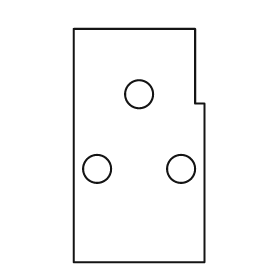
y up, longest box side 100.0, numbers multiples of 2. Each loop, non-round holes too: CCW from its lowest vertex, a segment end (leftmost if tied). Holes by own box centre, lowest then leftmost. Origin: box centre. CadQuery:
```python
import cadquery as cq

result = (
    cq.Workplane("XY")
    .moveTo(-28.0, -50.0)
    .lineTo(28.0, -50.0)
    .lineTo(28.0, 18.0)
    .lineTo(24.0, 18.0)
    .lineTo(24.0, 50.0)
    .lineTo(-28.0, 50.0)
    .close()
    .moveTo(-18.0, -10.0)
    .circle(6.0)
    .moveTo(18.0, -10.0)
    .circle(6.0)
    .moveTo(0.0, 22.0)
    .circle(6.0)
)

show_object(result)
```